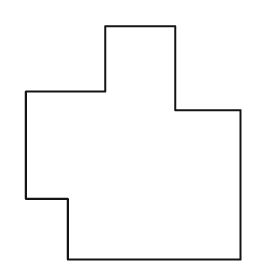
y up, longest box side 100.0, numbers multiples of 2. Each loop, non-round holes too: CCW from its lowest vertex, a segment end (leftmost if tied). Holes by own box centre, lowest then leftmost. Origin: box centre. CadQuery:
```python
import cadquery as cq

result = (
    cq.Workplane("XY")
    .moveTo(-28.0, -50.0)
    .lineTo(46.0, -50.0)
    .lineTo(46.0, 14.0)
    .lineTo(18.0, 14.0)
    .lineTo(18.0, 50.0)
    .lineTo(-12.0, 50.0)
    .lineTo(-12.0, 22.0)
    .lineTo(-46.0, 22.0)
    .lineTo(-46.0, -24.0)
    .lineTo(-28.0, -24.0)
    .close()
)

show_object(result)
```